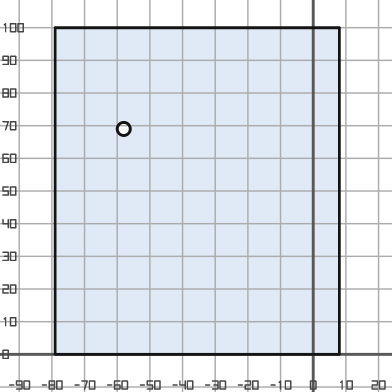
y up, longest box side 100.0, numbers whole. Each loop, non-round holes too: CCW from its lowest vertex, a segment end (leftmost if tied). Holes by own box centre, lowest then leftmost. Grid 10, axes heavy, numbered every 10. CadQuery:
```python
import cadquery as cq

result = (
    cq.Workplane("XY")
    .moveTo(-79.0, 0.0)
    .lineTo(8.0, 0.0)
    .lineTo(8.0, 100.0)
    .lineTo(-79.0, 100.0)
    .close()
    .moveTo(-58.0, 69.0)
    .circle(2.0)
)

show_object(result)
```